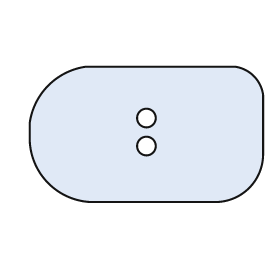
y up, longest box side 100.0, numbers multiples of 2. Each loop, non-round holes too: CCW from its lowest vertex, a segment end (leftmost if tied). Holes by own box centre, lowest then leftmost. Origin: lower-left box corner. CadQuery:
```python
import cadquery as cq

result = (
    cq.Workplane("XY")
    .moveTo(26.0, 0.0)
    .lineTo(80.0, 0.0)
    .threePointArc((94.0, 6.0), (100.0, 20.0))
    .lineTo(100.0, 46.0)
    .threePointArc((96.0, 54.0), (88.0, 58.0))
    .lineTo(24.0, 58.0)
    .threePointArc((8.0, 50.0), (0.0, 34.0))
    .lineTo(0.0, 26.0)
    .threePointArc((8.0, 8.0), (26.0, 0.0))
    .close()
    .moveTo(50.0, 24.0)
    .circle(4.0)
    .moveTo(50.0, 36.0)
    .circle(4.0)
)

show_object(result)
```